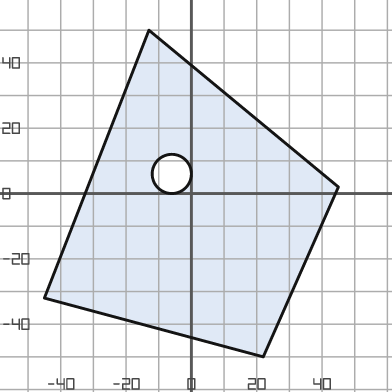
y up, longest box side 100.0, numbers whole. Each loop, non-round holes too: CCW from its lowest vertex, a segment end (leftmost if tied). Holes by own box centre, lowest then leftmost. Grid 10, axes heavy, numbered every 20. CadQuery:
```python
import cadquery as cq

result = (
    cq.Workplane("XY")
    .moveTo(22.0, -50.0)
    .lineTo(45.0, 2.0)
    .lineTo(-13.0, 50.0)
    .lineTo(-45.0, -32.0)
    .close()
    .moveTo(-6.0, 6.0)
    .circle(6.0)
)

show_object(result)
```